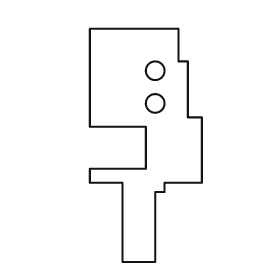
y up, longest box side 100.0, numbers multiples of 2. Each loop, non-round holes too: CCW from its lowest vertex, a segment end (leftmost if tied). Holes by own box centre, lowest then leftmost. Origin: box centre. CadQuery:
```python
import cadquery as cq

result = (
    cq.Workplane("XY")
    .moveTo(-10.0, -50.0)
    .lineTo(4.0, -50.0)
    .lineTo(4.0, -20.0)
    .lineTo(8.0, -20.0)
    .lineTo(8.0, -16.0)
    .lineTo(24.0, -16.0)
    .lineTo(24.0, 12.0)
    .lineTo(18.0, 12.0)
    .lineTo(18.0, 36.0)
    .lineTo(14.0, 36.0)
    .lineTo(14.0, 50.0)
    .lineTo(-24.0, 50.0)
    .lineTo(-24.0, 8.0)
    .lineTo(0.0, 8.0)
    .lineTo(0.0, -10.0)
    .lineTo(-24.0, -10.0)
    .lineTo(-24.0, -16.0)
    .lineTo(-10.0, -16.0)
    .close()
    .moveTo(4.0, 18.0)
    .circle(4.0)
    .moveTo(4.0, 32.0)
    .circle(4.0)
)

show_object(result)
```